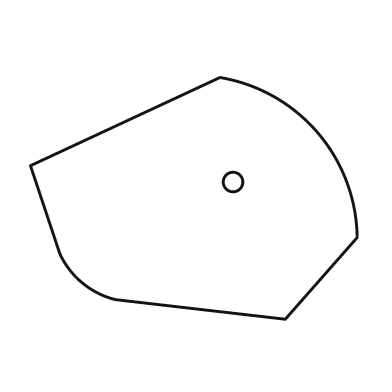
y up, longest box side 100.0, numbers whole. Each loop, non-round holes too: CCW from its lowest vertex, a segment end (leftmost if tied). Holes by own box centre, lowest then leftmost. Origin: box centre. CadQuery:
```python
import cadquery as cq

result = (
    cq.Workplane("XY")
    .moveTo(28.0, -37.0)
    .lineTo(50.0, -12.0)
    .threePointArc((38.0, 20.0), (8.0, 37.0))
    .lineTo(-50.0, 10.0)
    .lineTo(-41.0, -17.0)
    .threePointArc((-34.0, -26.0), (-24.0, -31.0))
    .close()
    .moveTo(12.0, 5.0)
    .circle(3.0)
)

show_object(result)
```